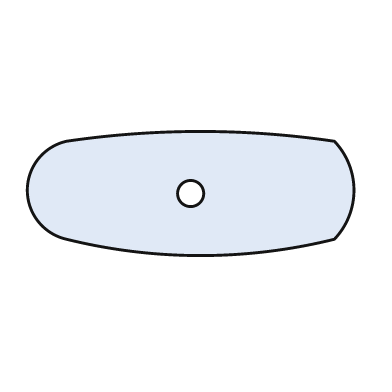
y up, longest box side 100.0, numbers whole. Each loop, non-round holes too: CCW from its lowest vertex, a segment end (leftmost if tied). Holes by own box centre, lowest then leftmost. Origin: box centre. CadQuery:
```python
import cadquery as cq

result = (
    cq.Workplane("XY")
    .moveTo(-38.0, -14.0)
    .threePointArc((3.0, -19.0), (44.0, -14.0))
    .threePointArc((50.0, 1.0), (44.0, 16.0))
    .threePointArc((3.0, 19.0), (-38.0, 16.0))
    .threePointArc((-50.0, 1.0), (-38.0, -14.0))
    .close()
    .moveTo(0.0, 0.0)
    .circle(4.0)
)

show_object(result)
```